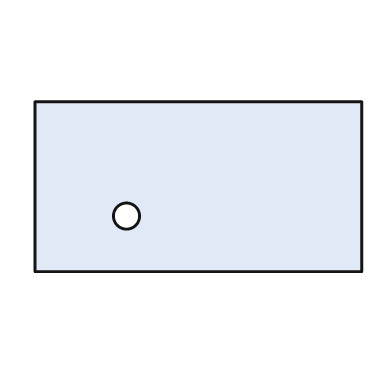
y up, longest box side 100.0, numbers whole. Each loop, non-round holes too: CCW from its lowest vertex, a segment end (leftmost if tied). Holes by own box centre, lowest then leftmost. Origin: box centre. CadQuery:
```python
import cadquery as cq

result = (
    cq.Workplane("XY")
    .moveTo(-50.0, -26.0)
    .lineTo(50.0, -26.0)
    .lineTo(50.0, 26.0)
    .lineTo(-50.0, 26.0)
    .close()
    .moveTo(-22.0, -9.0)
    .circle(4.0)
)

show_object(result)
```